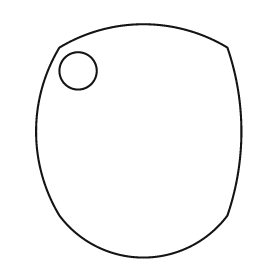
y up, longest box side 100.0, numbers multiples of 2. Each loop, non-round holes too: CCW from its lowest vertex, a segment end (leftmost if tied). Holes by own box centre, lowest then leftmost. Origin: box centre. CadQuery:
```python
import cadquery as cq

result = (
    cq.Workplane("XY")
    .moveTo(-34.0, -32.0)
    .threePointArc((2.0, -50.0), (38.0, -32.0))
    .threePointArc((44.0, 4.0), (38.0, 40.0))
    .threePointArc((2.0, 50.0), (-34.0, 40.0))
    .threePointArc((-44.0, 4.0), (-34.0, -32.0))
    .close()
    .moveTo(-26.0, 30.0)
    .circle(8.0)
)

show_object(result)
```